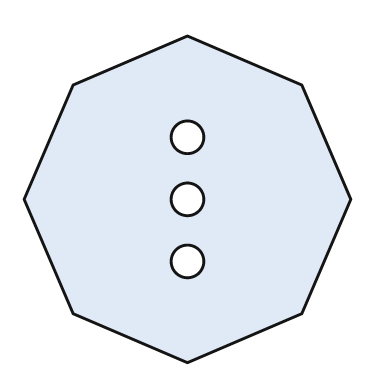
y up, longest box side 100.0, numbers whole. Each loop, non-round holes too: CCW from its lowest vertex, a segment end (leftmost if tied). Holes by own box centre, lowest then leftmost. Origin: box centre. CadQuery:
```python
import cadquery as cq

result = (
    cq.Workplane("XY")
    .moveTo(0.0, -50.0)
    .lineTo(35.0, -35.0)
    .lineTo(50.0, 0.0)
    .lineTo(35.0, 35.0)
    .lineTo(0.0, 50.0)
    .lineTo(-35.0, 35.0)
    .lineTo(-50.0, 0.0)
    .lineTo(-35.0, -35.0)
    .close()
    .moveTo(0.0, -19.0)
    .circle(5.0)
    .moveTo(0.0, 0.0)
    .circle(5.0)
    .moveTo(0.0, 19.0)
    .circle(5.0)
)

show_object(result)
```